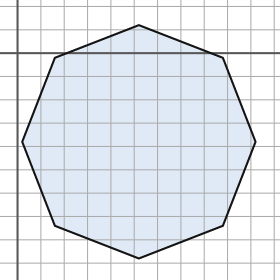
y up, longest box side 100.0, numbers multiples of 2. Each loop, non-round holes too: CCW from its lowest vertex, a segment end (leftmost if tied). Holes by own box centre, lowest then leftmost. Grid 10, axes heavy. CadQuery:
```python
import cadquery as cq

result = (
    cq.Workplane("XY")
    .moveTo(52.0, -88.0)
    .lineTo(88.0, -74.0)
    .lineTo(102.0, -38.0)
    .lineTo(88.0, -2.0)
    .lineTo(52.0, 12.0)
    .lineTo(16.0, -2.0)
    .lineTo(2.0, -38.0)
    .lineTo(16.0, -74.0)
    .close()
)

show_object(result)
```